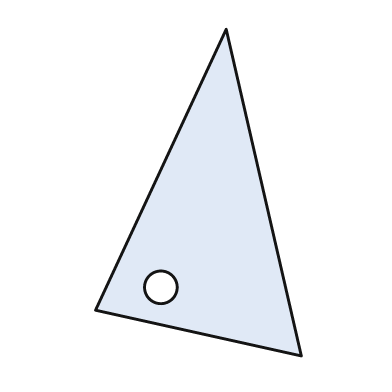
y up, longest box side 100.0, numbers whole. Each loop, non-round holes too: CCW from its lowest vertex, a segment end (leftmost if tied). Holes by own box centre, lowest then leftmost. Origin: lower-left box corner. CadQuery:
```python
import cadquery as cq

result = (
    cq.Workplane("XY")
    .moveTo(63.0, 0.0)
    .lineTo(40.0, 100.0)
    .lineTo(0.0, 14.0)
    .close()
    .moveTo(20.0, 21.0)
    .circle(5.0)
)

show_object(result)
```